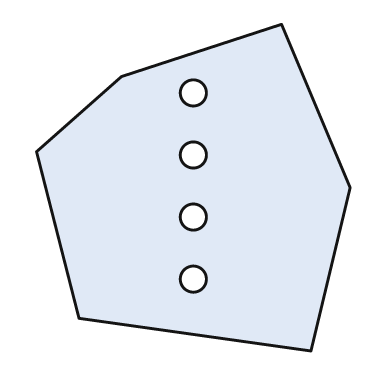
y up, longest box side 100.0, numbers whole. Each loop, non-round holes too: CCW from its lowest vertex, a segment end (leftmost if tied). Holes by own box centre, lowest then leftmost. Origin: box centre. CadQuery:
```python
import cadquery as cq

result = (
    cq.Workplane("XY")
    .moveTo(36.0, -50.0)
    .lineTo(48.0, 0.0)
    .lineTo(27.0, 50.0)
    .lineTo(-22.0, 34.0)
    .lineTo(-48.0, 11.0)
    .lineTo(-35.0, -40.0)
    .close()
    .moveTo(0.0, -28.0)
    .circle(4.0)
    .moveTo(0.0, -9.0)
    .circle(4.0)
    .moveTo(0.0, 10.0)
    .circle(4.0)
    .moveTo(0.0, 29.0)
    .circle(4.0)
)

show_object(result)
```